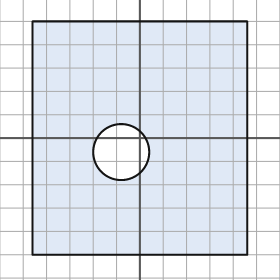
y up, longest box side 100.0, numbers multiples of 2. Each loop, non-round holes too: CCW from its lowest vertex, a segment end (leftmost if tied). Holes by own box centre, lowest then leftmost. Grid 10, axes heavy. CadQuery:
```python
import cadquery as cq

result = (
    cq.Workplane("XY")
    .moveTo(-46.0, -50.0)
    .lineTo(46.0, -50.0)
    .lineTo(46.0, 50.0)
    .lineTo(-46.0, 50.0)
    .close()
    .moveTo(-8.0, -6.0)
    .circle(12.0)
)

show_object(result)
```